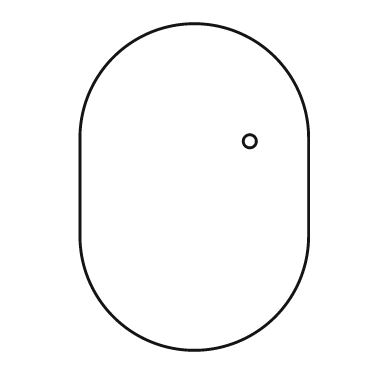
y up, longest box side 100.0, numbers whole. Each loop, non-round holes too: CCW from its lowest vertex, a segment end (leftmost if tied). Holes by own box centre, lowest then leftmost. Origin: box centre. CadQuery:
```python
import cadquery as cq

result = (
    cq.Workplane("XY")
    .moveTo(-35.0, -15.0)
    .threePointArc((0.0, -50.0), (35.0, -15.0))
    .lineTo(35.0, 15.0)
    .threePointArc((0.0, 50.0), (-35.0, 15.0))
    .close()
    .moveTo(17.0, 14.0)
    .circle(2.0)
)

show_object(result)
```